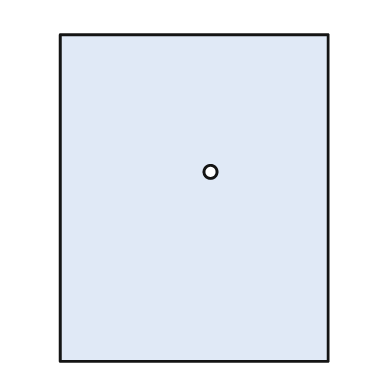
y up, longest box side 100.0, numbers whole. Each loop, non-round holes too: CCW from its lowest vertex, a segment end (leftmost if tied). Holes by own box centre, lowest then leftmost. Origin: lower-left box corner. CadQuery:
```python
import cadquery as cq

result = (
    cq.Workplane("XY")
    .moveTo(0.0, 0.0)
    .lineTo(82.0, 0.0)
    .lineTo(82.0, 100.0)
    .lineTo(0.0, 100.0)
    .close()
    .moveTo(46.0, 58.0)
    .circle(2.0)
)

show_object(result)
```